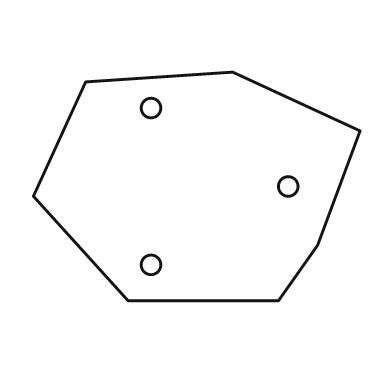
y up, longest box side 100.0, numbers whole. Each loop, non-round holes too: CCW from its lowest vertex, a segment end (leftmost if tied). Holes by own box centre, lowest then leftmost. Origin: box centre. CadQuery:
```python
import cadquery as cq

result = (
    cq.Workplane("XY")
    .moveTo(-21.0, -35.0)
    .lineTo(25.0, -35.0)
    .lineTo(37.0, -18.0)
    .lineTo(50.0, 17.0)
    .lineTo(11.0, 35.0)
    .lineTo(-34.0, 32.0)
    .lineTo(-50.0, -3.0)
    .close()
    .moveTo(-14.0, -24.0)
    .circle(3.0)
    .moveTo(28.0, 0.0)
    .circle(3.0)
    .moveTo(-14.0, 24.0)
    .circle(3.0)
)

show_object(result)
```